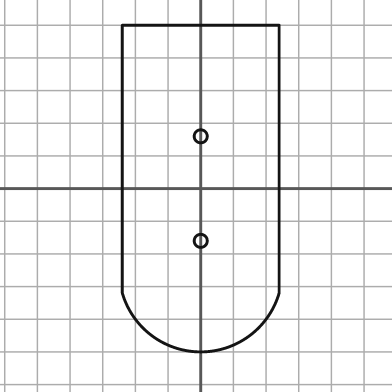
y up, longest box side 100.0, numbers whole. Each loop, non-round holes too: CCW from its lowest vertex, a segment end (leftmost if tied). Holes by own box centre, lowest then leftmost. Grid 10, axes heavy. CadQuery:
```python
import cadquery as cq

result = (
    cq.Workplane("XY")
    .moveTo(-24.0, -32.0)
    .threePointArc((0.0, -50.0), (24.0, -32.0))
    .lineTo(24.0, 50.0)
    .lineTo(-24.0, 50.0)
    .close()
    .moveTo(0.0, -16.0)
    .circle(2.0)
    .moveTo(0.0, 16.0)
    .circle(2.0)
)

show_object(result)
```